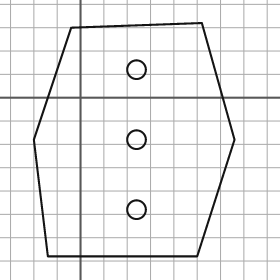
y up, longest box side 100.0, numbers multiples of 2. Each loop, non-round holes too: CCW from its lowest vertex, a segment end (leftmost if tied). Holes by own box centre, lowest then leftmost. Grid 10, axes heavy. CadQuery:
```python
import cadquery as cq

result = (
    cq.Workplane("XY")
    .moveTo(-14.0, -68.0)
    .lineTo(50.0, -68.0)
    .lineTo(66.0, -18.0)
    .lineTo(52.0, 32.0)
    .lineTo(-4.0, 30.0)
    .lineTo(-20.0, -18.0)
    .close()
    .moveTo(24.0, -48.0)
    .circle(4.0)
    .moveTo(24.0, -18.0)
    .circle(4.0)
    .moveTo(24.0, 12.0)
    .circle(4.0)
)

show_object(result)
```